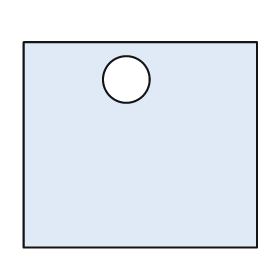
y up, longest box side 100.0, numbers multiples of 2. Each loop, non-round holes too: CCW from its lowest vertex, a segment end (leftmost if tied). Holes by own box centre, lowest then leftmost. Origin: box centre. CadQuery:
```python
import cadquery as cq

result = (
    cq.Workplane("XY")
    .moveTo(-50.0, -44.0)
    .lineTo(50.0, -44.0)
    .lineTo(50.0, 44.0)
    .lineTo(-50.0, 44.0)
    .close()
    .moveTo(-6.0, 28.0)
    .circle(10.0)
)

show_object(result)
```